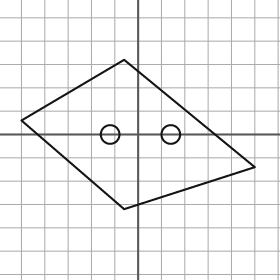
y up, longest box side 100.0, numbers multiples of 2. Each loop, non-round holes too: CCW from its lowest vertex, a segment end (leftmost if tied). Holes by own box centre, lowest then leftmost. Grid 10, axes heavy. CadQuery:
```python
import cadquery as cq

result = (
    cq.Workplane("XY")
    .moveTo(-6.0, -32.0)
    .lineTo(50.0, -14.0)
    .lineTo(-6.0, 32.0)
    .lineTo(-50.0, 6.0)
    .close()
    .moveTo(-12.0, 0.0)
    .circle(4.0)
    .moveTo(14.0, 0.0)
    .circle(4.0)
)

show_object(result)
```